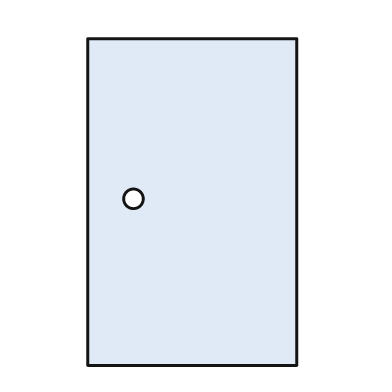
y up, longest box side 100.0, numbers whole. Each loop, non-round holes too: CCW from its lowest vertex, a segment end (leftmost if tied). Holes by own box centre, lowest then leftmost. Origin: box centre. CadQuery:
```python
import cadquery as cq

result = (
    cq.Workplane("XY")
    .moveTo(-32.0, -50.0)
    .lineTo(32.0, -50.0)
    .lineTo(32.0, 50.0)
    .lineTo(-32.0, 50.0)
    .close()
    .moveTo(-18.0, 1.0)
    .circle(3.0)
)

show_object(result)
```